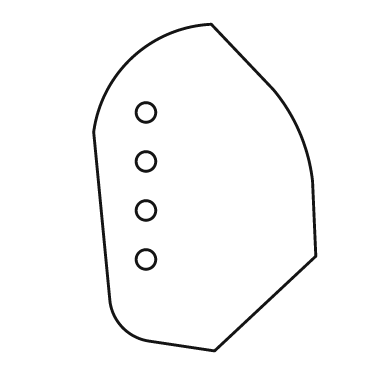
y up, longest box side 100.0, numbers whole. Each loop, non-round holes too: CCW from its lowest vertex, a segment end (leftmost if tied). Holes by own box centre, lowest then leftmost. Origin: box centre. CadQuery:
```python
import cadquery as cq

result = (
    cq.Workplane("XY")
    .moveTo(3.0, -50.0)
    .lineTo(34.0, -21.0)
    .lineTo(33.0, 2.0)
    .threePointArc((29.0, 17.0), (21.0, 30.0))
    .lineTo(2.0, 50.0)
    .threePointArc((-22.0, 40.0), (-34.0, 17.0))
    .lineTo(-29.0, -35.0)
    .threePointArc((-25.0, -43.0), (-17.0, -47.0))
    .close()
    .moveTo(-18.0, -22.0)
    .circle(3.0)
    .moveTo(-18.0, -7.0)
    .circle(3.0)
    .moveTo(-18.0, 8.0)
    .circle(3.0)
    .moveTo(-18.0, 23.0)
    .circle(3.0)
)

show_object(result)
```